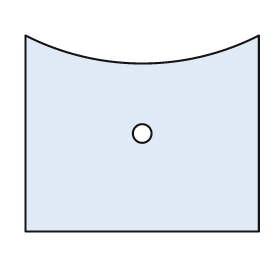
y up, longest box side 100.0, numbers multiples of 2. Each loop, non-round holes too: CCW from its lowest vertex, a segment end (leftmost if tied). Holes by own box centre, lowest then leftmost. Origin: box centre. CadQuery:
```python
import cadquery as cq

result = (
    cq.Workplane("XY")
    .moveTo(-50.0, -42.0)
    .lineTo(50.0, -42.0)
    .lineTo(50.0, 42.0)
    .threePointArc((0.0, 30.0), (-50.0, 42.0))
    .close()
    .moveTo(0.0, 0.0)
    .circle(4.0)
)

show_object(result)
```